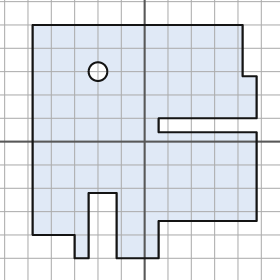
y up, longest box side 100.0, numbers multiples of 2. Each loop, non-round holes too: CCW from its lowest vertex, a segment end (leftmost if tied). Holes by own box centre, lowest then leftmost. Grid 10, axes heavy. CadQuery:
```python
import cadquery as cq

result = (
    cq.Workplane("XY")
    .moveTo(-30.0, -50.0)
    .lineTo(-24.0, -50.0)
    .lineTo(-24.0, -22.0)
    .lineTo(-12.0, -22.0)
    .lineTo(-12.0, -50.0)
    .lineTo(6.0, -50.0)
    .lineTo(6.0, -34.0)
    .lineTo(48.0, -34.0)
    .lineTo(48.0, 4.0)
    .lineTo(6.0, 4.0)
    .lineTo(6.0, 10.0)
    .lineTo(48.0, 10.0)
    .lineTo(48.0, 28.0)
    .lineTo(42.0, 28.0)
    .lineTo(42.0, 50.0)
    .lineTo(-48.0, 50.0)
    .lineTo(-48.0, -40.0)
    .lineTo(-30.0, -40.0)
    .close()
    .moveTo(-20.0, 30.0)
    .circle(4.0)
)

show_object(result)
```